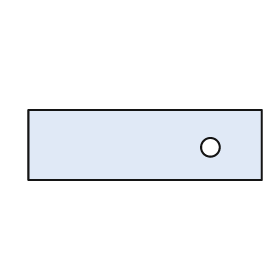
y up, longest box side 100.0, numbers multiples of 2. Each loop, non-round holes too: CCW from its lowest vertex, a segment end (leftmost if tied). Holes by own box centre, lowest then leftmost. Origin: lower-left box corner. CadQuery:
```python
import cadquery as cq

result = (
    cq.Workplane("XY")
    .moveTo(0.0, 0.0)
    .lineTo(100.0, 0.0)
    .lineTo(100.0, 30.0)
    .lineTo(0.0, 30.0)
    .close()
    .moveTo(78.0, 14.0)
    .circle(4.0)
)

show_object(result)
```